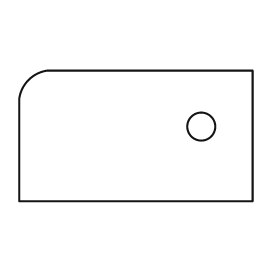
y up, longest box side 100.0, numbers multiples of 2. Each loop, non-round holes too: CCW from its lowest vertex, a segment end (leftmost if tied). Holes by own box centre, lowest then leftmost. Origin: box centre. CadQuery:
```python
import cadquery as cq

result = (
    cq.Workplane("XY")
    .moveTo(-50.0, -28.0)
    .lineTo(50.0, -28.0)
    .lineTo(50.0, 28.0)
    .lineTo(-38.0, 28.0)
    .threePointArc((-46.0, 24.0), (-50.0, 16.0))
    .close()
    .moveTo(28.0, 4.0)
    .circle(6.0)
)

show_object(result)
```